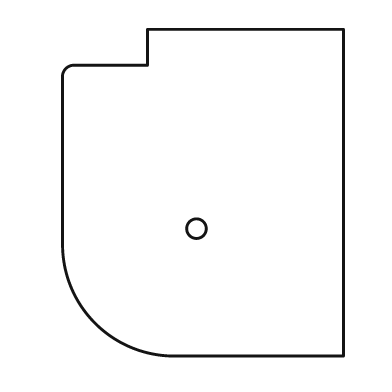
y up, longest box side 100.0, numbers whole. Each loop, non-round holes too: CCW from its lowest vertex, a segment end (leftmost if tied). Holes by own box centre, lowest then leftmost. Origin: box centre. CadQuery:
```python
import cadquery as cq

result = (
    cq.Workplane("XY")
    .moveTo(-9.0, -50.0)
    .lineTo(43.0, -50.0)
    .lineTo(43.0, 50.0)
    .lineTo(-17.0, 50.0)
    .lineTo(-17.0, 39.0)
    .lineTo(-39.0, 39.0)
    .threePointArc((-42.0, 38.0), (-43.0, 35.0))
    .lineTo(-43.0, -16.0)
    .threePointArc((-33.0, -40.0), (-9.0, -50.0))
    .close()
    .moveTo(-2.0, -11.0)
    .circle(3.0)
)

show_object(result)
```